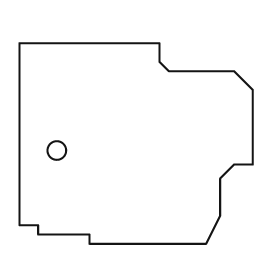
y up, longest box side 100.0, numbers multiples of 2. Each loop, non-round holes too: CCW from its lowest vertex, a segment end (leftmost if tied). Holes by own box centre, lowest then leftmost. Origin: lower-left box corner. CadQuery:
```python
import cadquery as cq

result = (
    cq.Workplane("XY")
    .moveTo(30.0, 0.0)
    .lineTo(80.0, 0.0)
    .lineTo(86.0, 12.0)
    .lineTo(86.0, 28.0)
    .lineTo(92.0, 34.0)
    .lineTo(100.0, 34.0)
    .lineTo(100.0, 66.0)
    .lineTo(92.0, 74.0)
    .lineTo(64.0, 74.0)
    .lineTo(60.0, 78.0)
    .lineTo(60.0, 86.0)
    .lineTo(0.0, 86.0)
    .lineTo(0.0, 8.0)
    .lineTo(8.0, 8.0)
    .lineTo(8.0, 4.0)
    .lineTo(30.0, 4.0)
    .close()
    .moveTo(16.0, 40.0)
    .circle(4.0)
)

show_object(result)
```